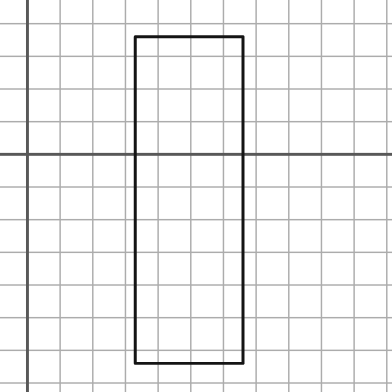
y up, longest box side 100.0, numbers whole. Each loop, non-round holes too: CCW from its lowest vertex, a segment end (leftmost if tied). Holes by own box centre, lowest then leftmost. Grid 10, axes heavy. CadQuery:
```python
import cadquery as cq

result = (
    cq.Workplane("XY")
    .moveTo(33.0, -64.0)
    .lineTo(66.0, -64.0)
    .lineTo(66.0, 36.0)
    .lineTo(33.0, 36.0)
    .close()
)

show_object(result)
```